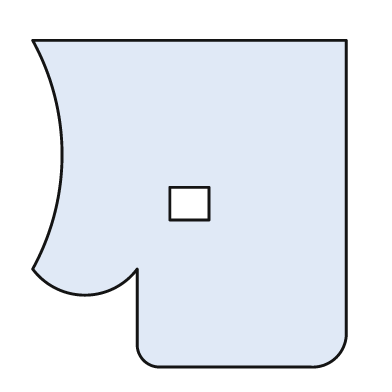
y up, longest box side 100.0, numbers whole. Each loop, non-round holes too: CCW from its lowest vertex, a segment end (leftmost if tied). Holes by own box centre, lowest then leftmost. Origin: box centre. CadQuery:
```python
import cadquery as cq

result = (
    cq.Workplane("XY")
    .moveTo(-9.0, -50.0)
    .lineTo(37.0, -50.0)
    .threePointArc((45.0, -47.0), (48.0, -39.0))
    .lineTo(48.0, 50.0)
    .lineTo(-48.0, 50.0)
    .threePointArc((-39.0, 15.0), (-48.0, -20.0))
    .threePointArc((-32.0, -28.0), (-16.0, -20.0))
    .lineTo(-16.0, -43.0)
    .threePointArc((-14.0, -48.0), (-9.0, -50.0))
    .close()
    .moveTo(-6.0, -5.0)
    .lineTo(6.0, -5.0)
    .lineTo(6.0, 5.0)
    .lineTo(-6.0, 5.0)
    .close()
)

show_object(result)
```